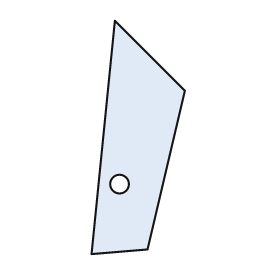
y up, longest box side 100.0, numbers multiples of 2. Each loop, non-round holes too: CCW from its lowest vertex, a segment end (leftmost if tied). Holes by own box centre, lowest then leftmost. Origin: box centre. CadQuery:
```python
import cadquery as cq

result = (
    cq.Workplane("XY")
    .moveTo(-20.0, -50.0)
    .lineTo(4.0, -48.0)
    .lineTo(20.0, 20.0)
    .lineTo(-10.0, 50.0)
    .close()
    .moveTo(-8.0, -20.0)
    .circle(4.0)
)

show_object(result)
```